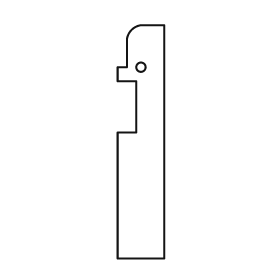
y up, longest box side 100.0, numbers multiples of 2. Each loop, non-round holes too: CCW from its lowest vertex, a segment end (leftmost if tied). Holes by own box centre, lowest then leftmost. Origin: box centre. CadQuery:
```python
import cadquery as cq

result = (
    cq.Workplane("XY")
    .moveTo(-10.0, -50.0)
    .lineTo(10.0, -50.0)
    .lineTo(10.0, 50.0)
    .lineTo(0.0, 50.0)
    .threePointArc((-4.0, 48.0), (-6.0, 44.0))
    .lineTo(-6.0, 32.0)
    .lineTo(-10.0, 32.0)
    .lineTo(-10.0, 26.0)
    .lineTo(-2.0, 26.0)
    .lineTo(-2.0, 4.0)
    .lineTo(-10.0, 4.0)
    .close()
    .moveTo(0.0, 32.0)
    .circle(2.0)
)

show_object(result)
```